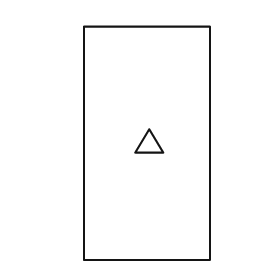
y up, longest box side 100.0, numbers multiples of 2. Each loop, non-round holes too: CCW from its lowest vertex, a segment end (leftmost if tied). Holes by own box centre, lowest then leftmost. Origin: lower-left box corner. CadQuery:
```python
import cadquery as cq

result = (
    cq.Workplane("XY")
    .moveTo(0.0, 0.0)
    .lineTo(54.0, 0.0)
    .lineTo(54.0, 100.0)
    .lineTo(0.0, 100.0)
    .close()
    .moveTo(22.0, 46.0)
    .lineTo(34.0, 46.0)
    .lineTo(28.0, 56.0)
    .close()
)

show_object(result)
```